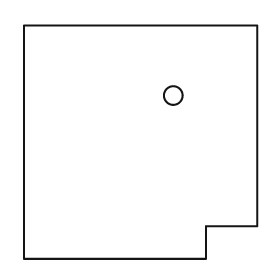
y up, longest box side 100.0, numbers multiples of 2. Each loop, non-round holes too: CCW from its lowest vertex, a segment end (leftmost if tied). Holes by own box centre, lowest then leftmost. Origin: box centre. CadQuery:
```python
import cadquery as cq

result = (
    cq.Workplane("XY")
    .moveTo(-50.0, -50.0)
    .lineTo(28.0, -50.0)
    .lineTo(28.0, -36.0)
    .lineTo(50.0, -36.0)
    .lineTo(50.0, 50.0)
    .lineTo(-50.0, 50.0)
    .close()
    .moveTo(14.0, 20.0)
    .circle(4.0)
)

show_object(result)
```